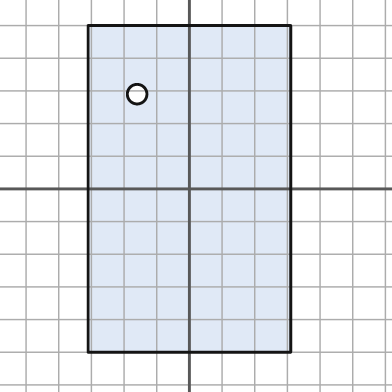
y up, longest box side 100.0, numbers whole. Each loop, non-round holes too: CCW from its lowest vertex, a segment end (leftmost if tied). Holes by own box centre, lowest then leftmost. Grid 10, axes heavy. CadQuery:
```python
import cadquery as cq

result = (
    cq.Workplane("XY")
    .moveTo(-31.0, -50.0)
    .lineTo(31.0, -50.0)
    .lineTo(31.0, 50.0)
    .lineTo(-31.0, 50.0)
    .close()
    .moveTo(-16.0, 29.0)
    .circle(3.0)
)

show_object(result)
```